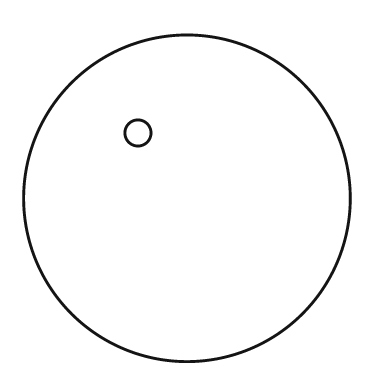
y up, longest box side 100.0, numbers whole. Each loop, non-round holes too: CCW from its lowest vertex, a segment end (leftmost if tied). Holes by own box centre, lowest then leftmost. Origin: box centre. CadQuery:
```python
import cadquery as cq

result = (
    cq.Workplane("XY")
    .moveTo(0.0, 0.0)
    .circle(50.0)
    .moveTo(-15.0, 20.0)
    .circle(4.0)
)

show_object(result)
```